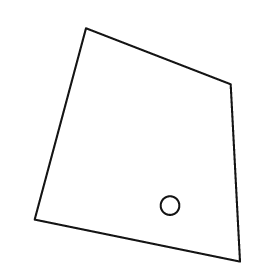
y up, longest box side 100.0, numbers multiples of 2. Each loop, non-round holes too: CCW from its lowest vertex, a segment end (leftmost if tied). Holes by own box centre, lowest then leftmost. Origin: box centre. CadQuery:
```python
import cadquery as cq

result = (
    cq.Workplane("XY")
    .moveTo(44.0, -50.0)
    .lineTo(40.0, 26.0)
    .lineTo(-22.0, 50.0)
    .lineTo(-44.0, -32.0)
    .close()
    .moveTo(14.0, -26.0)
    .circle(4.0)
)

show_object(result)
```